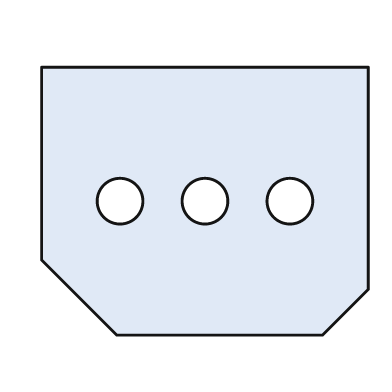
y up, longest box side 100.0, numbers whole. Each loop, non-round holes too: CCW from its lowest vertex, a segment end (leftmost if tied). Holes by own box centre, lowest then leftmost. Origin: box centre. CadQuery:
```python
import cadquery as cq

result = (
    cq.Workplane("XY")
    .moveTo(-27.0, -41.0)
    .lineTo(36.0, -41.0)
    .lineTo(50.0, -27.0)
    .lineTo(50.0, 41.0)
    .lineTo(-50.0, 41.0)
    .lineTo(-50.0, -18.0)
    .close()
    .moveTo(-26.0, 0.0)
    .circle(7.0)
    .moveTo(0.0, 0.0)
    .circle(7.0)
    .moveTo(26.0, 0.0)
    .circle(7.0)
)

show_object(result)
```